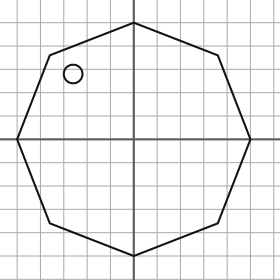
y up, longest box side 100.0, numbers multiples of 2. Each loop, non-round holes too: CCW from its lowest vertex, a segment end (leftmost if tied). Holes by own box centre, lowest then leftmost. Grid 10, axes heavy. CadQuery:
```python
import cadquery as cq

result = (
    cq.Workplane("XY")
    .moveTo(0.0, -50.0)
    .lineTo(36.0, -36.0)
    .lineTo(50.0, 0.0)
    .lineTo(36.0, 36.0)
    .lineTo(0.0, 50.0)
    .lineTo(-36.0, 36.0)
    .lineTo(-50.0, 0.0)
    .lineTo(-36.0, -36.0)
    .close()
    .moveTo(-26.0, 28.0)
    .circle(4.0)
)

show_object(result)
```